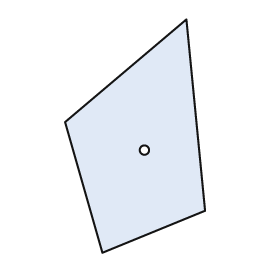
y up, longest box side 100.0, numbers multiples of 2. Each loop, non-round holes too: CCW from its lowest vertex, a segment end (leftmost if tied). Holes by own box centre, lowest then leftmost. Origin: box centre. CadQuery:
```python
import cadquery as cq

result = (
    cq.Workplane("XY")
    .moveTo(-14.0, -50.0)
    .lineTo(30.0, -32.0)
    .lineTo(22.0, 50.0)
    .lineTo(-30.0, 6.0)
    .close()
    .moveTo(4.0, -6.0)
    .circle(2.0)
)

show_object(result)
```